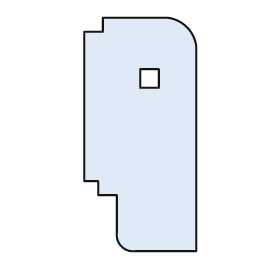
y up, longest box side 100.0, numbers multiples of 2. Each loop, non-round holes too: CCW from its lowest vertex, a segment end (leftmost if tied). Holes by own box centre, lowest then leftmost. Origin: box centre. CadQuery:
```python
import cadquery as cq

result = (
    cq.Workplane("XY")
    .moveTo(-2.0, -50.0)
    .lineTo(24.0, -50.0)
    .lineTo(24.0, 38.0)
    .threePointArc((20.0, 46.0), (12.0, 50.0))
    .lineTo(-16.0, 50.0)
    .lineTo(-16.0, 44.0)
    .lineTo(-24.0, 44.0)
    .lineTo(-24.0, -20.0)
    .lineTo(-18.0, -20.0)
    .lineTo(-18.0, -26.0)
    .lineTo(-10.0, -26.0)
    .lineTo(-10.0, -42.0)
    .threePointArc((-8.0, -48.0), (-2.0, -50.0))
    .close()
    .moveTo(0.0, 20.0)
    .lineTo(8.0, 20.0)
    .lineTo(8.0, 28.0)
    .lineTo(0.0, 28.0)
    .close()
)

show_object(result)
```